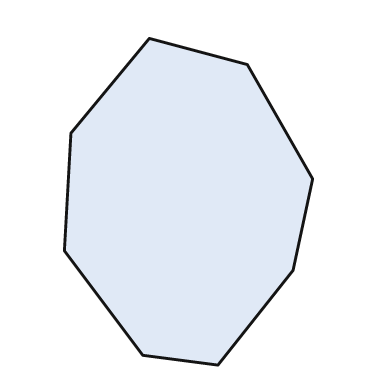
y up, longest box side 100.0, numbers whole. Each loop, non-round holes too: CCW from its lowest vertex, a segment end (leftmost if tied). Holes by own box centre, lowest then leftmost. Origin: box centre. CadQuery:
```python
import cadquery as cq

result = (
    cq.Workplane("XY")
    .moveTo(9.0, -50.0)
    .lineTo(32.0, -21.0)
    .lineTo(38.0, 7.0)
    .lineTo(18.0, 42.0)
    .lineTo(-12.0, 50.0)
    .lineTo(-36.0, 21.0)
    .lineTo(-38.0, -15.0)
    .lineTo(-14.0, -47.0)
    .close()
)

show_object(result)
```